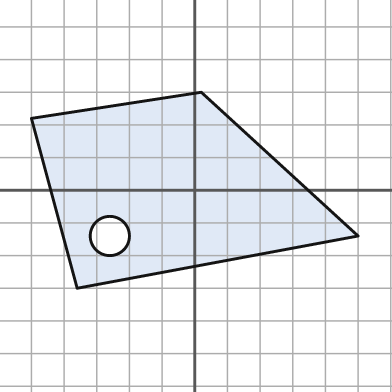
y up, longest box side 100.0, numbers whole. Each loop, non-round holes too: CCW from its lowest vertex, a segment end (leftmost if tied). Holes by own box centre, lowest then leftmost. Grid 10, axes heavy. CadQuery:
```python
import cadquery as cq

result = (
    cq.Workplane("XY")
    .moveTo(-36.0, -30.0)
    .lineTo(50.0, -14.0)
    .lineTo(2.0, 30.0)
    .lineTo(-50.0, 22.0)
    .close()
    .moveTo(-26.0, -14.0)
    .circle(6.0)
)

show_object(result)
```